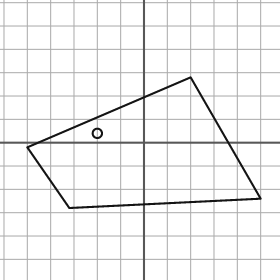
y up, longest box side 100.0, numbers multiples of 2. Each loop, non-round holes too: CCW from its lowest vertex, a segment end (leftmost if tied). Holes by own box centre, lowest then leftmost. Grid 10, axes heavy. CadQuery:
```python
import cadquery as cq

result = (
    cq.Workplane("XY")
    .moveTo(-32.0, -28.0)
    .lineTo(50.0, -24.0)
    .lineTo(20.0, 28.0)
    .lineTo(-50.0, -2.0)
    .close()
    .moveTo(-20.0, 4.0)
    .circle(2.0)
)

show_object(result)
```